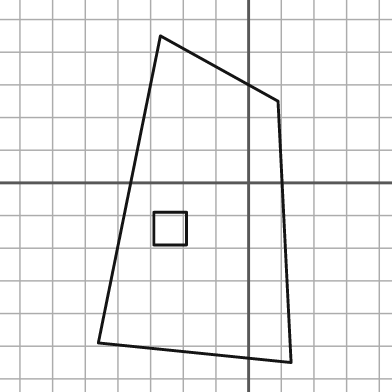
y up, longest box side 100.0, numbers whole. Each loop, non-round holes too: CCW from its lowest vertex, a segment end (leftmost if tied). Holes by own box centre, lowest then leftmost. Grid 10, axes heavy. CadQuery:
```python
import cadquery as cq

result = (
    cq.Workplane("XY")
    .moveTo(13.0, -55.0)
    .lineTo(9.0, 25.0)
    .lineTo(-27.0, 45.0)
    .lineTo(-46.0, -49.0)
    .close()
    .moveTo(-29.0, -19.0)
    .lineTo(-19.0, -19.0)
    .lineTo(-19.0, -9.0)
    .lineTo(-29.0, -9.0)
    .close()
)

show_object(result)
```